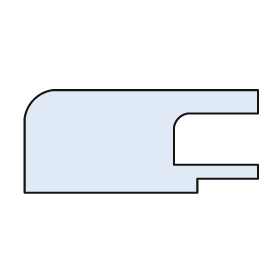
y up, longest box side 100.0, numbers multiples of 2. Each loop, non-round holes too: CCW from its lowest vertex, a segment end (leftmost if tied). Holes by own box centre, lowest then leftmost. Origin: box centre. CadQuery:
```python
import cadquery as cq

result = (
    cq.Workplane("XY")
    .moveTo(-50.0, -22.0)
    .lineTo(24.0, -22.0)
    .lineTo(24.0, -16.0)
    .lineTo(50.0, -16.0)
    .lineTo(50.0, -10.0)
    .lineTo(14.0, -10.0)
    .lineTo(14.0, 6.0)
    .threePointArc((16.0, 10.0), (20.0, 12.0))
    .lineTo(50.0, 12.0)
    .lineTo(50.0, 22.0)
    .lineTo(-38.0, 22.0)
    .threePointArc((-46.0, 18.0), (-50.0, 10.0))
    .close()
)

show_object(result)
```